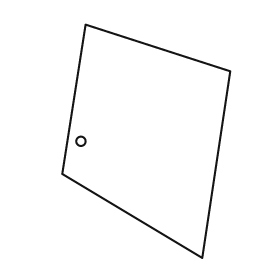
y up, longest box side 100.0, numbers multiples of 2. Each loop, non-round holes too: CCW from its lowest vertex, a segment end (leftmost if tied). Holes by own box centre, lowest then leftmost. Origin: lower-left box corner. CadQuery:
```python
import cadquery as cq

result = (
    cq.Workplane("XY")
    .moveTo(60.0, 0.0)
    .lineTo(72.0, 80.0)
    .lineTo(10.0, 100.0)
    .lineTo(0.0, 36.0)
    .close()
    .moveTo(8.0, 50.0)
    .circle(2.0)
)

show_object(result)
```